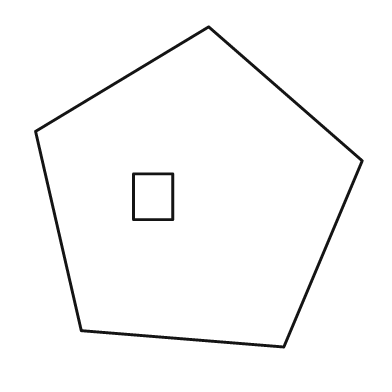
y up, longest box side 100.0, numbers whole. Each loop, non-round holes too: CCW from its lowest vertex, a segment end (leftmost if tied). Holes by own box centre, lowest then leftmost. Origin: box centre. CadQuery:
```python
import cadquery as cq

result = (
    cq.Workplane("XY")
    .moveTo(26.0, -49.0)
    .lineTo(50.0, 8.0)
    .lineTo(3.0, 49.0)
    .lineTo(-50.0, 17.0)
    .lineTo(-36.0, -44.0)
    .close()
    .moveTo(-20.0, -10.0)
    .lineTo(-8.0, -10.0)
    .lineTo(-8.0, 4.0)
    .lineTo(-20.0, 4.0)
    .close()
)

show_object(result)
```